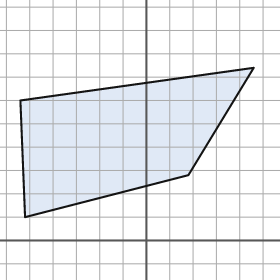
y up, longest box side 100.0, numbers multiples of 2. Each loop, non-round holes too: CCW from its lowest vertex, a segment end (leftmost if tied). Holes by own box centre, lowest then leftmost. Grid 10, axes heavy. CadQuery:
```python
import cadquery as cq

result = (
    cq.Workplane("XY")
    .moveTo(-52.0, 10.0)
    .lineTo(18.0, 28.0)
    .lineTo(46.0, 74.0)
    .lineTo(-54.0, 60.0)
    .close()
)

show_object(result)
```